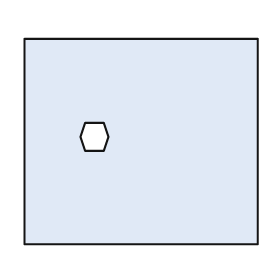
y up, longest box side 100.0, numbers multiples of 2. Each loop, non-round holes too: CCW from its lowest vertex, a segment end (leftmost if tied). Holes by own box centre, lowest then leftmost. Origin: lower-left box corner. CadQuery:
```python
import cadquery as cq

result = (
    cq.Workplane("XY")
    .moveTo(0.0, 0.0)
    .lineTo(100.0, 0.0)
    .lineTo(100.0, 88.0)
    .lineTo(0.0, 88.0)
    .close()
    .moveTo(26.0, 40.0)
    .lineTo(34.0, 40.0)
    .lineTo(36.0, 46.0)
    .lineTo(34.0, 52.0)
    .lineTo(26.0, 52.0)
    .lineTo(24.0, 46.0)
    .close()
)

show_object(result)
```